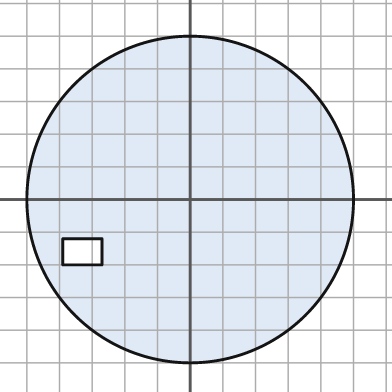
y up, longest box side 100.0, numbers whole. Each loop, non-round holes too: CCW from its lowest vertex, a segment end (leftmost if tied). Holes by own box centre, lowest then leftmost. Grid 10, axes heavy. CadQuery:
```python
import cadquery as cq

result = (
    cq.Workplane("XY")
    .moveTo(0.0, 0.0)
    .circle(50.0)
    .moveTo(-39.0, -20.0)
    .lineTo(-27.0, -20.0)
    .lineTo(-27.0, -12.0)
    .lineTo(-39.0, -12.0)
    .close()
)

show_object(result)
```